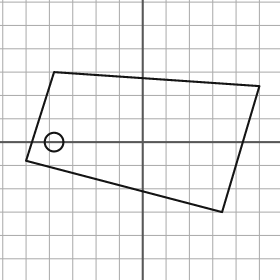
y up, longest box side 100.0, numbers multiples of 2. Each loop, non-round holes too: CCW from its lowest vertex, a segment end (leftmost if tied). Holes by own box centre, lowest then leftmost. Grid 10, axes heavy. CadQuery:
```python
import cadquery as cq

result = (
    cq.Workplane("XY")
    .moveTo(34.0, -30.0)
    .lineTo(50.0, 24.0)
    .lineTo(-38.0, 30.0)
    .lineTo(-50.0, -8.0)
    .close()
    .moveTo(-38.0, 0.0)
    .circle(4.0)
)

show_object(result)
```